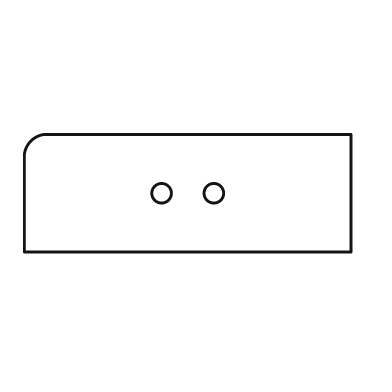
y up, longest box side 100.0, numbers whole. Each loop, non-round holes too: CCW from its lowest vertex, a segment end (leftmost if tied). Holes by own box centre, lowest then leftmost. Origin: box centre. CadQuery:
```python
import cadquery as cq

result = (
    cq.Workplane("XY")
    .moveTo(-50.0, -18.0)
    .lineTo(50.0, -18.0)
    .lineTo(50.0, 18.0)
    .lineTo(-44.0, 18.0)
    .threePointArc((-48.0, 16.0), (-50.0, 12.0))
    .close()
    .moveTo(-8.0, 0.0)
    .circle(3.0)
    .moveTo(8.0, 0.0)
    .circle(3.0)
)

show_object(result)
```